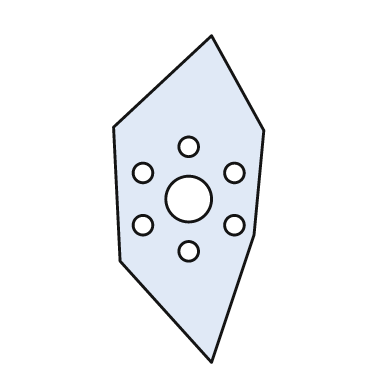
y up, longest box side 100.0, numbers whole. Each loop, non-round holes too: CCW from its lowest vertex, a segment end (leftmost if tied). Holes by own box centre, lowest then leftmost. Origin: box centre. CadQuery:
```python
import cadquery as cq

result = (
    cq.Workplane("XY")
    .moveTo(7.0, -50.0)
    .lineTo(20.0, -11.0)
    .lineTo(23.0, 21.0)
    .lineTo(7.0, 50.0)
    .lineTo(-23.0, 22.0)
    .lineTo(-21.0, -19.0)
    .close()
    .moveTo(0.0, -16.0)
    .circle(3.0)
    .moveTo(-14.0, -8.0)
    .circle(3.0)
    .moveTo(14.0, -8.0)
    .circle(3.0)
    .moveTo(0.0, 0.0)
    .circle(7.0)
    .moveTo(-14.0, 8.0)
    .circle(3.0)
    .moveTo(14.0, 8.0)
    .circle(3.0)
    .moveTo(0.0, 16.0)
    .circle(3.0)
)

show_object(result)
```